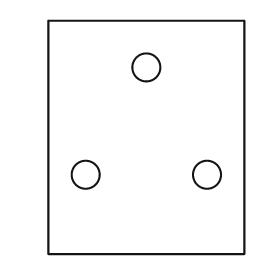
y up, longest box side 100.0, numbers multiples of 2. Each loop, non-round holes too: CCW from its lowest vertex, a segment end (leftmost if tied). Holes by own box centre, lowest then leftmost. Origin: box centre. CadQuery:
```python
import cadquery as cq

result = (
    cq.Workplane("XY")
    .moveTo(-42.0, -50.0)
    .lineTo(42.0, -50.0)
    .lineTo(42.0, 50.0)
    .lineTo(-42.0, 50.0)
    .close()
    .moveTo(-26.0, -16.0)
    .circle(6.0)
    .moveTo(26.0, -16.0)
    .circle(6.0)
    .moveTo(0.0, 30.0)
    .circle(6.0)
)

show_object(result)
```